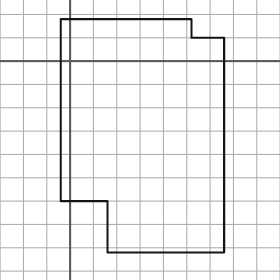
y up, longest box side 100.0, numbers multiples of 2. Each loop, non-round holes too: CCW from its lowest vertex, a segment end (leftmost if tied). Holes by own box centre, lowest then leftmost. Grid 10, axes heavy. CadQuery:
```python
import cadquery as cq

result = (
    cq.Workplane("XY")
    .moveTo(16.0, -82.0)
    .lineTo(66.0, -82.0)
    .lineTo(66.0, 10.0)
    .lineTo(52.0, 10.0)
    .lineTo(52.0, 18.0)
    .lineTo(-4.0, 18.0)
    .lineTo(-4.0, -60.0)
    .lineTo(16.0, -60.0)
    .close()
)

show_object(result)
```